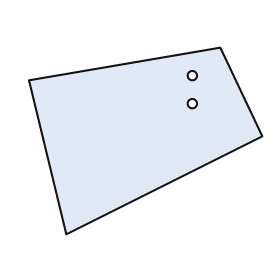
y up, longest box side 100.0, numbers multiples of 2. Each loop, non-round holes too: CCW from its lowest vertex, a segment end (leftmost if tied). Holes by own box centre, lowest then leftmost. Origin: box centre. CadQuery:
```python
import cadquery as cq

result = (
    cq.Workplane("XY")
    .moveTo(-34.0, -40.0)
    .lineTo(50.0, 2.0)
    .lineTo(32.0, 40.0)
    .lineTo(-50.0, 26.0)
    .close()
    .moveTo(20.0, 16.0)
    .circle(2.0)
    .moveTo(20.0, 28.0)
    .circle(2.0)
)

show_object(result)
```